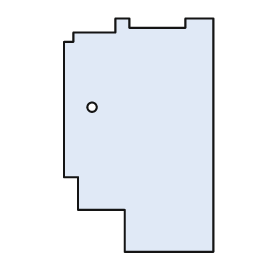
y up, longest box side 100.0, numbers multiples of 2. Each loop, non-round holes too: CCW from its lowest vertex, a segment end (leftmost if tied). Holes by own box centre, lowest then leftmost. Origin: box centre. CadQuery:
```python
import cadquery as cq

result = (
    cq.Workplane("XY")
    .moveTo(-6.0, -50.0)
    .lineTo(32.0, -50.0)
    .lineTo(32.0, 50.0)
    .lineTo(20.0, 50.0)
    .lineTo(20.0, 46.0)
    .lineTo(-4.0, 46.0)
    .lineTo(-4.0, 50.0)
    .lineTo(-10.0, 50.0)
    .lineTo(-10.0, 44.0)
    .lineTo(-28.0, 44.0)
    .lineTo(-28.0, 40.0)
    .lineTo(-32.0, 40.0)
    .lineTo(-32.0, -18.0)
    .lineTo(-26.0, -18.0)
    .lineTo(-26.0, -32.0)
    .lineTo(-6.0, -32.0)
    .close()
    .moveTo(-20.0, 12.0)
    .circle(2.0)
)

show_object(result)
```